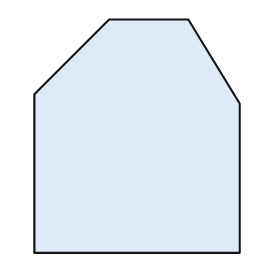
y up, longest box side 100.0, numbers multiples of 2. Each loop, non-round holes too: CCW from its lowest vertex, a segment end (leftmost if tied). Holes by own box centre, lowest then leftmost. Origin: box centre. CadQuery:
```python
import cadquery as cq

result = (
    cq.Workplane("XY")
    .moveTo(-44.0, -50.0)
    .lineTo(44.0, -50.0)
    .lineTo(44.0, 14.0)
    .lineTo(22.0, 50.0)
    .lineTo(-12.0, 50.0)
    .lineTo(-44.0, 18.0)
    .close()
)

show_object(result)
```